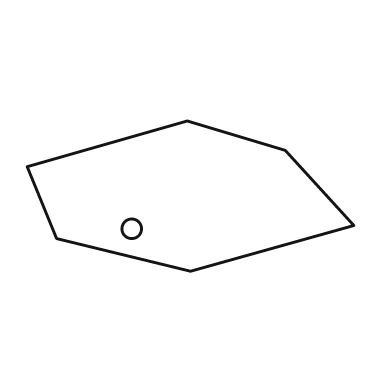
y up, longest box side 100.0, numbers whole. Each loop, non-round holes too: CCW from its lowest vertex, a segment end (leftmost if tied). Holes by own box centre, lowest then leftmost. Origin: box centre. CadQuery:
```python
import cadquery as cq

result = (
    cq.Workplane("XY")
    .moveTo(0.0, -23.0)
    .lineTo(50.0, -9.0)
    .lineTo(29.0, 14.0)
    .lineTo(-1.0, 23.0)
    .lineTo(-50.0, 9.0)
    .lineTo(-41.0, -13.0)
    .close()
    .moveTo(-18.0, -10.0)
    .circle(3.0)
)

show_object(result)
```